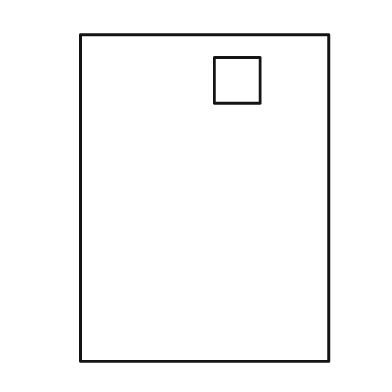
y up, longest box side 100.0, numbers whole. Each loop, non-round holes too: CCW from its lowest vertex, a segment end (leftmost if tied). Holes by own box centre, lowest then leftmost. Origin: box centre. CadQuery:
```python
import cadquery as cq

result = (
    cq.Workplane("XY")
    .moveTo(-38.0, -50.0)
    .lineTo(38.0, -50.0)
    .lineTo(38.0, 50.0)
    .lineTo(-38.0, 50.0)
    .close()
    .moveTo(3.0, 29.0)
    .lineTo(17.0, 29.0)
    .lineTo(17.0, 43.0)
    .lineTo(3.0, 43.0)
    .close()
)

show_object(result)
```